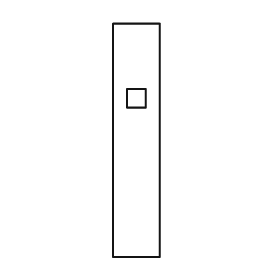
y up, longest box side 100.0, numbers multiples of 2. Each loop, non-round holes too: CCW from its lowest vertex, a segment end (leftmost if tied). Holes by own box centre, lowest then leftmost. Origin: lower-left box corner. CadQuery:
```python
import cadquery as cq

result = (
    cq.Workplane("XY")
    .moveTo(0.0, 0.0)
    .lineTo(20.0, 0.0)
    .lineTo(20.0, 100.0)
    .lineTo(0.0, 100.0)
    .close()
    .moveTo(6.0, 64.0)
    .lineTo(14.0, 64.0)
    .lineTo(14.0, 72.0)
    .lineTo(6.0, 72.0)
    .close()
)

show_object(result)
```